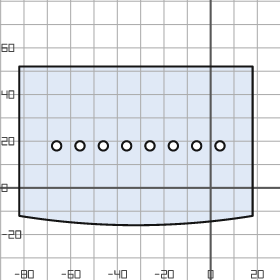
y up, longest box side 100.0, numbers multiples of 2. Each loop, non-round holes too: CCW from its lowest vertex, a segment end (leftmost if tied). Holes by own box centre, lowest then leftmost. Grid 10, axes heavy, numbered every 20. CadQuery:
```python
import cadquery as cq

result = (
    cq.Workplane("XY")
    .moveTo(-82.0, -12.0)
    .threePointArc((-32.0, -16.0), (18.0, -12.0))
    .lineTo(18.0, 52.0)
    .lineTo(-82.0, 52.0)
    .close()
    .moveTo(-66.0, 18.0)
    .circle(2.0)
    .moveTo(-56.0, 18.0)
    .circle(2.0)
    .moveTo(-46.0, 18.0)
    .circle(2.0)
    .moveTo(-36.0, 18.0)
    .circle(2.0)
    .moveTo(-26.0, 18.0)
    .circle(2.0)
    .moveTo(-16.0, 18.0)
    .circle(2.0)
    .moveTo(-6.0, 18.0)
    .circle(2.0)
    .moveTo(4.0, 18.0)
    .circle(2.0)
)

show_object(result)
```